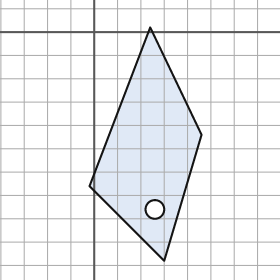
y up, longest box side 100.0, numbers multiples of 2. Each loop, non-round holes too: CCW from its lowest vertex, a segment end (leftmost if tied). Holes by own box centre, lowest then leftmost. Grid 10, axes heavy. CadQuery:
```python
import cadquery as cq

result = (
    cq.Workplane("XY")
    .moveTo(30.0, -98.0)
    .lineTo(46.0, -44.0)
    .lineTo(24.0, 2.0)
    .lineTo(-2.0, -66.0)
    .close()
    .moveTo(26.0, -76.0)
    .circle(4.0)
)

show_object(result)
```